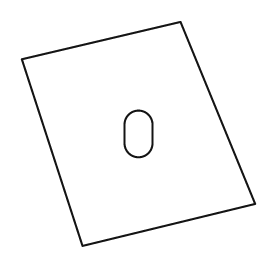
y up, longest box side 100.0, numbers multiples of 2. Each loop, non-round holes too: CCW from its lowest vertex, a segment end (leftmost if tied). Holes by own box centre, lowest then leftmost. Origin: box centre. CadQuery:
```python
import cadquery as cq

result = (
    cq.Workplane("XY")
    .moveTo(-24.0, -48.0)
    .lineTo(50.0, -30.0)
    .lineTo(18.0, 48.0)
    .lineTo(-50.0, 32.0)
    .close()
    .moveTo(-6.0, -4.0)
    .threePointArc((0.0, -10.0), (6.0, -4.0))
    .lineTo(6.0, 4.0)
    .threePointArc((0.0, 10.0), (-6.0, 4.0))
    .close()
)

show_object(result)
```